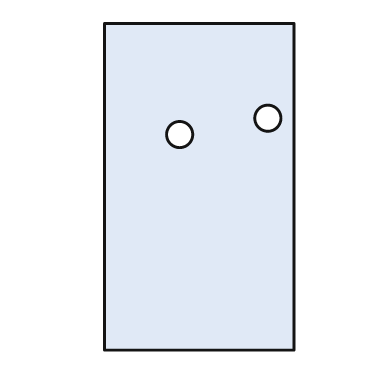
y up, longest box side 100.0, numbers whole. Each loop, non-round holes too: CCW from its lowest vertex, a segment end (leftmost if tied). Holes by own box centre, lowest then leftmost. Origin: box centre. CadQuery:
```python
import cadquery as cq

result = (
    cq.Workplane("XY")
    .moveTo(-29.0, -50.0)
    .lineTo(29.0, -50.0)
    .lineTo(29.0, 50.0)
    .lineTo(-29.0, 50.0)
    .close()
    .moveTo(-6.0, 16.0)
    .circle(4.0)
    .moveTo(21.0, 21.0)
    .circle(4.0)
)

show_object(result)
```